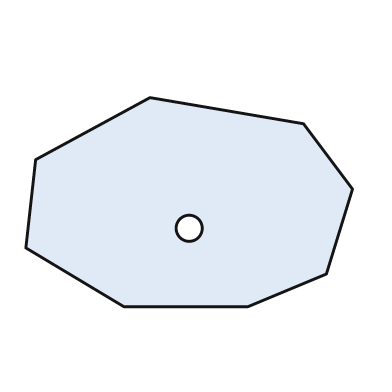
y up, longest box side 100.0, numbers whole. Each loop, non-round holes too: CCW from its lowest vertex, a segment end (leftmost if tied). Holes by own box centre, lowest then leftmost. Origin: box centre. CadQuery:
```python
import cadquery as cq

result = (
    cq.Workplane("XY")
    .moveTo(-20.0, -32.0)
    .lineTo(18.0, -32.0)
    .lineTo(42.0, -22.0)
    .lineTo(50.0, 4.0)
    .lineTo(35.0, 24.0)
    .lineTo(-12.0, 32.0)
    .lineTo(-47.0, 13.0)
    .lineTo(-50.0, -14.0)
    .close()
    .moveTo(0.0, -8.0)
    .circle(4.0)
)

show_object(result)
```